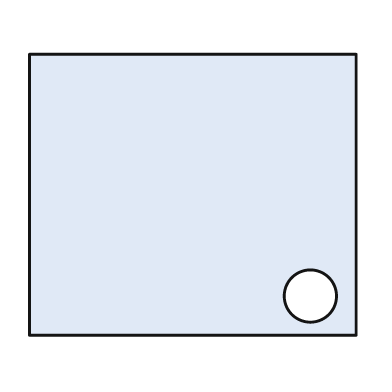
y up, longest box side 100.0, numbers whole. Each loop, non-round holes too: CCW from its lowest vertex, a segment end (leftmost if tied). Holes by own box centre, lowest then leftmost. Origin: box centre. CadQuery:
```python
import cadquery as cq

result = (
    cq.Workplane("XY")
    .moveTo(-50.0, -43.0)
    .lineTo(50.0, -43.0)
    .lineTo(50.0, 43.0)
    .lineTo(-50.0, 43.0)
    .close()
    .moveTo(36.0, -31.0)
    .circle(8.0)
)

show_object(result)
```